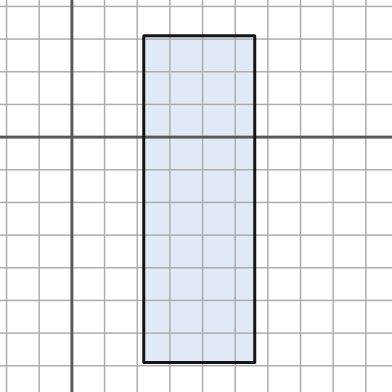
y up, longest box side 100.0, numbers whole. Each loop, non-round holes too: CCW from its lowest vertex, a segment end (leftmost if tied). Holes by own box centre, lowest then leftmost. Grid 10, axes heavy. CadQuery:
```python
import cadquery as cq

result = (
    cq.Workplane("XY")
    .moveTo(22.0, -69.0)
    .lineTo(56.0, -69.0)
    .lineTo(56.0, 31.0)
    .lineTo(22.0, 31.0)
    .close()
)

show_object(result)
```